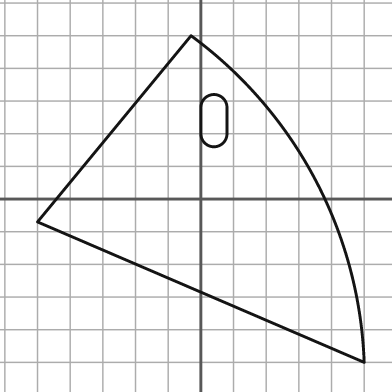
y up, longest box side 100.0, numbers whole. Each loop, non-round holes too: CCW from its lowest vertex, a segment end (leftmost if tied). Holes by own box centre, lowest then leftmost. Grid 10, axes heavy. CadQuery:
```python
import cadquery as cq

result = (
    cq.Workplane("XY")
    .moveTo(50.0, -50.0)
    .threePointArc((35.0, 6.0), (-3.0, 50.0))
    .lineTo(-50.0, -7.0)
    .close()
    .moveTo(0.0, 20.0)
    .threePointArc((4.0, 16.0), (8.0, 20.0))
    .lineTo(8.0, 28.0)
    .threePointArc((4.0, 32.0), (0.0, 28.0))
    .close()
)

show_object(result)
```